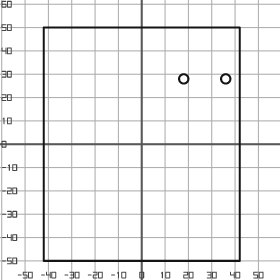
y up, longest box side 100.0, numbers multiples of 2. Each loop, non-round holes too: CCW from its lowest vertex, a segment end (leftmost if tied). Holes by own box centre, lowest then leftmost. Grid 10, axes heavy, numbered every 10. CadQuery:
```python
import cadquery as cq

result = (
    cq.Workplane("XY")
    .moveTo(-42.0, -50.0)
    .lineTo(42.0, -50.0)
    .lineTo(42.0, 50.0)
    .lineTo(-42.0, 50.0)
    .close()
    .moveTo(18.0, 28.0)
    .circle(2.0)
    .moveTo(36.0, 28.0)
    .circle(2.0)
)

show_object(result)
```